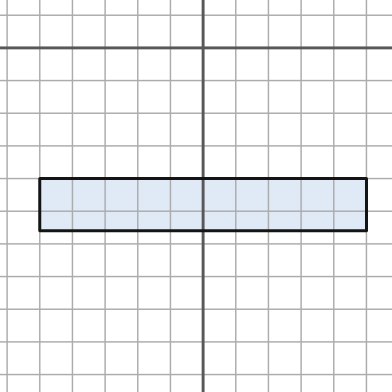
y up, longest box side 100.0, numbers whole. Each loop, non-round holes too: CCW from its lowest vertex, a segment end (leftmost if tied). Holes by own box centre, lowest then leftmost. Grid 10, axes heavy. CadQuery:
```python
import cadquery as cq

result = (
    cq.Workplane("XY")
    .moveTo(-50.0, -56.0)
    .lineTo(50.0, -56.0)
    .lineTo(50.0, -40.0)
    .lineTo(-50.0, -40.0)
    .close()
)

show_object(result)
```